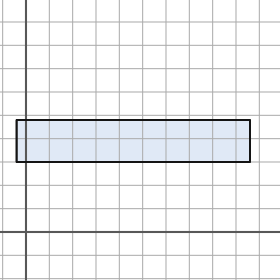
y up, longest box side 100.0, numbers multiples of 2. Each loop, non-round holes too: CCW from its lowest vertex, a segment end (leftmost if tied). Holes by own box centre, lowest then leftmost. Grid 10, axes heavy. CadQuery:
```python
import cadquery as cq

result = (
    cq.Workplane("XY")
    .moveTo(-4.0, 30.0)
    .lineTo(96.0, 30.0)
    .lineTo(96.0, 48.0)
    .lineTo(-4.0, 48.0)
    .close()
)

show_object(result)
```